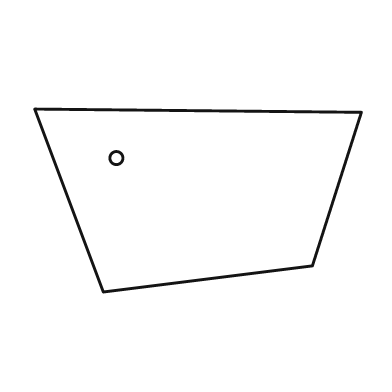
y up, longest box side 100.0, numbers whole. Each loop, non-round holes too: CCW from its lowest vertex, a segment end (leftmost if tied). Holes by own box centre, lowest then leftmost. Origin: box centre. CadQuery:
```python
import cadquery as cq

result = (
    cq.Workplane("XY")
    .moveTo(-29.0, -28.0)
    .lineTo(35.0, -20.0)
    .lineTo(50.0, 27.0)
    .lineTo(-50.0, 28.0)
    .close()
    .moveTo(-25.0, 13.0)
    .circle(2.0)
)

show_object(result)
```